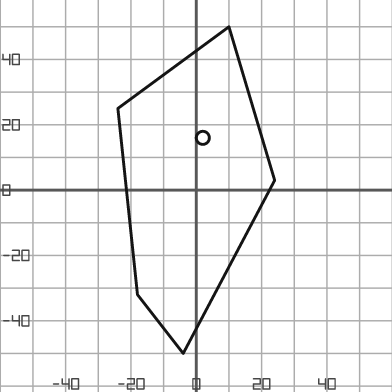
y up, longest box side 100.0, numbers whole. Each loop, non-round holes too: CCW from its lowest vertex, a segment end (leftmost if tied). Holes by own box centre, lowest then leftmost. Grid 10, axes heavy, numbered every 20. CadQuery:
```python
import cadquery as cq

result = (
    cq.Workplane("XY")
    .moveTo(-4.0, -50.0)
    .lineTo(24.0, 3.0)
    .lineTo(10.0, 50.0)
    .lineTo(-24.0, 25.0)
    .lineTo(-18.0, -32.0)
    .close()
    .moveTo(2.0, 16.0)
    .circle(2.0)
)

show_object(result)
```